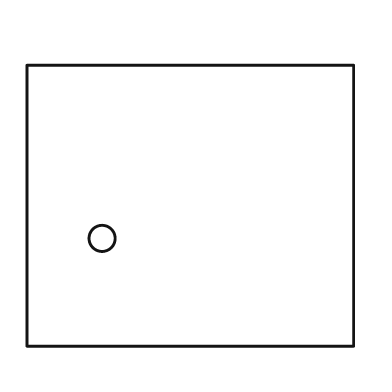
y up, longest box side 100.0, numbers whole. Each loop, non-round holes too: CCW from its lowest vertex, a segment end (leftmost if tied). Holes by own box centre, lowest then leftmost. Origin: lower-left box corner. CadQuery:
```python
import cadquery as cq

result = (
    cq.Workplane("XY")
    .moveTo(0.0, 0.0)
    .lineTo(100.0, 0.0)
    .lineTo(100.0, 86.0)
    .lineTo(0.0, 86.0)
    .close()
    .moveTo(23.0, 33.0)
    .circle(4.0)
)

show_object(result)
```